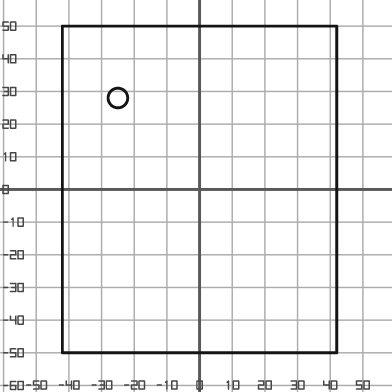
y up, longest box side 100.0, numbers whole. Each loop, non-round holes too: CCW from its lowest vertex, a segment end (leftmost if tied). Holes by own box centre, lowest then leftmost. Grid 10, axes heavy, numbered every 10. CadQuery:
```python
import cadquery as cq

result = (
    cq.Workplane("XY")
    .moveTo(-42.0, -50.0)
    .lineTo(42.0, -50.0)
    .lineTo(42.0, 50.0)
    .lineTo(-42.0, 50.0)
    .close()
    .moveTo(-25.0, 28.0)
    .circle(3.0)
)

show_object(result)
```